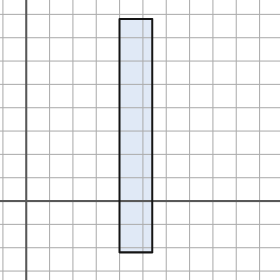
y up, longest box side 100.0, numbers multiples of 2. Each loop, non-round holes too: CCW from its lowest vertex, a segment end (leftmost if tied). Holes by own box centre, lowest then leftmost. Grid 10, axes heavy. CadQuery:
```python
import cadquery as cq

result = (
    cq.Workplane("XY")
    .moveTo(40.0, -22.0)
    .lineTo(54.0, -22.0)
    .lineTo(54.0, 78.0)
    .lineTo(40.0, 78.0)
    .close()
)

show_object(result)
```